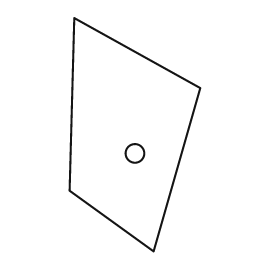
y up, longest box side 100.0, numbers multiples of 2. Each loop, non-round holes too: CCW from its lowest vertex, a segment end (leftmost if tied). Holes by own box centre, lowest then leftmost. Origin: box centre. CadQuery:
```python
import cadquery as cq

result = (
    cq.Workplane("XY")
    .moveTo(8.0, -50.0)
    .lineTo(28.0, 20.0)
    .lineTo(-26.0, 50.0)
    .lineTo(-28.0, -24.0)
    .close()
    .moveTo(0.0, -8.0)
    .circle(4.0)
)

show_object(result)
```